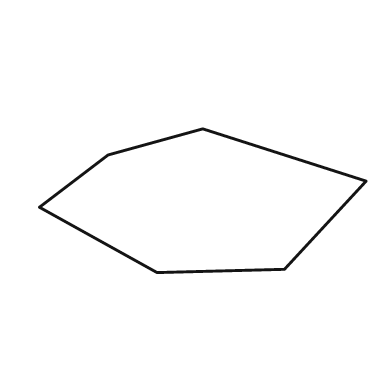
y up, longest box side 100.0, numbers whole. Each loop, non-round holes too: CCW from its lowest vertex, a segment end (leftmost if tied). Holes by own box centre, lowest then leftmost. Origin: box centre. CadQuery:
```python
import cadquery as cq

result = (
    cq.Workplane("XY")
    .moveTo(-14.0, -22.0)
    .lineTo(25.0, -21.0)
    .lineTo(50.0, 6.0)
    .lineTo(0.0, 22.0)
    .lineTo(-29.0, 14.0)
    .lineTo(-50.0, -2.0)
    .close()
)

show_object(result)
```